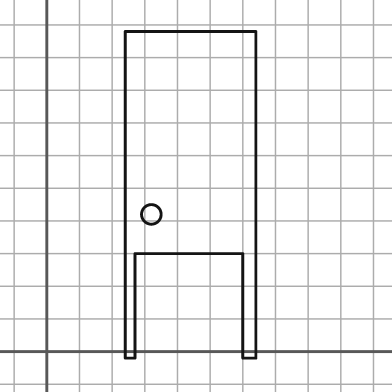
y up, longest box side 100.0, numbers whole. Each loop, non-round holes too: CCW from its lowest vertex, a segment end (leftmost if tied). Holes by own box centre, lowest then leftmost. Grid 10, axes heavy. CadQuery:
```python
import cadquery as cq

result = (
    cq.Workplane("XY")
    .moveTo(24.0, -2.0)
    .lineTo(27.0, -2.0)
    .lineTo(27.0, 30.0)
    .lineTo(60.0, 30.0)
    .lineTo(60.0, -2.0)
    .lineTo(64.0, -2.0)
    .lineTo(64.0, 98.0)
    .lineTo(24.0, 98.0)
    .close()
    .moveTo(32.0, 42.0)
    .circle(3.0)
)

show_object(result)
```